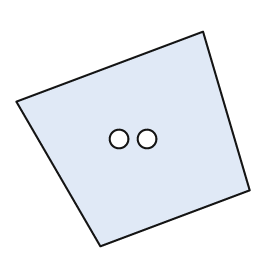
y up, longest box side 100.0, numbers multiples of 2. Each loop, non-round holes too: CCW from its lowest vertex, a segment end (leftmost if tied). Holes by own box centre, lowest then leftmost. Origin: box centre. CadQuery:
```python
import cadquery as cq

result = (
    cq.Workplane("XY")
    .moveTo(-14.0, -46.0)
    .lineTo(50.0, -22.0)
    .lineTo(30.0, 46.0)
    .lineTo(-50.0, 16.0)
    .close()
    .moveTo(-6.0, 0.0)
    .circle(4.0)
    .moveTo(6.0, 0.0)
    .circle(4.0)
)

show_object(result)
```